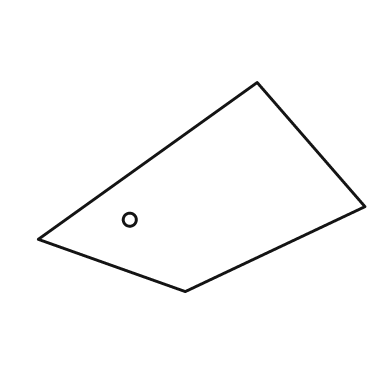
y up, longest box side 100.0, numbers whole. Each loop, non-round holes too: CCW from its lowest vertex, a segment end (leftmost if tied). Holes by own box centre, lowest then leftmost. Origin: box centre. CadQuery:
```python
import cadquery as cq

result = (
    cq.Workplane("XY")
    .moveTo(-5.0, -32.0)
    .lineTo(50.0, -6.0)
    .lineTo(17.0, 32.0)
    .lineTo(-50.0, -16.0)
    .close()
    .moveTo(-22.0, -10.0)
    .circle(2.0)
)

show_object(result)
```